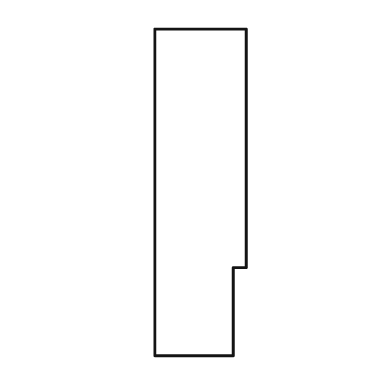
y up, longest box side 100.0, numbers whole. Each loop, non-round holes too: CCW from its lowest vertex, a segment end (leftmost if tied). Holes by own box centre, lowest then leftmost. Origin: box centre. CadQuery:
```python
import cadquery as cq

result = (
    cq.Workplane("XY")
    .moveTo(-14.0, -50.0)
    .lineTo(10.0, -50.0)
    .lineTo(10.0, -23.0)
    .lineTo(14.0, -23.0)
    .lineTo(14.0, 50.0)
    .lineTo(-14.0, 50.0)
    .close()
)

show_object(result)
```